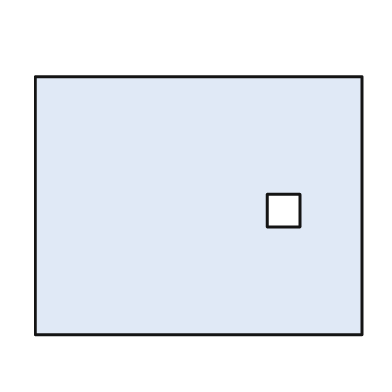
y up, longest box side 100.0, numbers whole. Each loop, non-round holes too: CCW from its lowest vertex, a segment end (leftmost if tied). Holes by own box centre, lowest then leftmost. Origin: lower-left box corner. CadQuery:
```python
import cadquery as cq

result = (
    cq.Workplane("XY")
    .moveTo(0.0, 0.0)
    .lineTo(100.0, 0.0)
    .lineTo(100.0, 79.0)
    .lineTo(0.0, 79.0)
    .close()
    .moveTo(71.0, 33.0)
    .lineTo(81.0, 33.0)
    .lineTo(81.0, 43.0)
    .lineTo(71.0, 43.0)
    .close()
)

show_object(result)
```